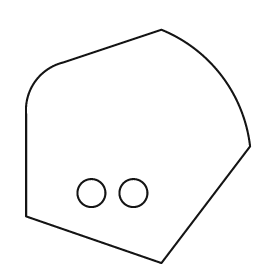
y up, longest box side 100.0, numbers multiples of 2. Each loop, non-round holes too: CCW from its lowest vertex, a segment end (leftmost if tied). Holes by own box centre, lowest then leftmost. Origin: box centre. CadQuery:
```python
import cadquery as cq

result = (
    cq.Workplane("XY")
    .moveTo(10.0, -50.0)
    .lineTo(48.0, 0.0)
    .threePointArc((36.0, 30.0), (10.0, 50.0))
    .lineTo(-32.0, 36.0)
    .threePointArc((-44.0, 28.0), (-48.0, 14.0))
    .lineTo(-48.0, -30.0)
    .close()
    .moveTo(-20.0, -20.0)
    .circle(6.0)
    .moveTo(-2.0, -20.0)
    .circle(6.0)
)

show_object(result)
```